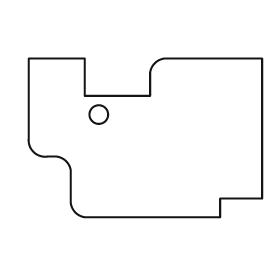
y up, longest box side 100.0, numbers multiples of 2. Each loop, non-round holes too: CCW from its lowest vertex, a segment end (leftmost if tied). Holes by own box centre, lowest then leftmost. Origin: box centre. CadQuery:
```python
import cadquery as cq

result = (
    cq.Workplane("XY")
    .moveTo(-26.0, -34.0)
    .lineTo(32.0, -34.0)
    .lineTo(32.0, -26.0)
    .lineTo(50.0, -26.0)
    .lineTo(50.0, 34.0)
    .lineTo(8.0, 34.0)
    .threePointArc((4.0, 32.0), (2.0, 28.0))
    .lineTo(2.0, 18.0)
    .lineTo(-26.0, 18.0)
    .lineTo(-26.0, 34.0)
    .lineTo(-50.0, 34.0)
    .lineTo(-50.0, 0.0)
    .threePointArc((-48.0, -6.0), (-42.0, -8.0))
    .lineTo(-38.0, -8.0)
    .threePointArc((-34.0, -10.0), (-32.0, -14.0))
    .lineTo(-32.0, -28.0)
    .threePointArc((-30.0, -32.0), (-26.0, -34.0))
    .close()
    .moveTo(-20.0, 10.0)
    .circle(4.0)
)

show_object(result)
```